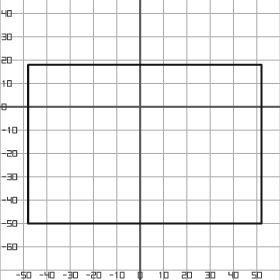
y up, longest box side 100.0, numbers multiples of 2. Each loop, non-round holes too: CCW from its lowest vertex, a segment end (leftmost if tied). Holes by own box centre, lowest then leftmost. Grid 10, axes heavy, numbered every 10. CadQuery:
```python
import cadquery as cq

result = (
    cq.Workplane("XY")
    .moveTo(-48.0, -50.0)
    .lineTo(52.0, -50.0)
    .lineTo(52.0, 18.0)
    .lineTo(-48.0, 18.0)
    .close()
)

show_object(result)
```